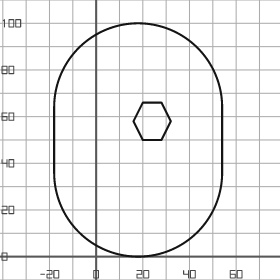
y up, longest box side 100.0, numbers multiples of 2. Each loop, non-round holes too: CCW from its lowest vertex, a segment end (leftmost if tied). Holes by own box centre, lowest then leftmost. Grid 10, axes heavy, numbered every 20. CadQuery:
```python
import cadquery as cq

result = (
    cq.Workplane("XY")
    .moveTo(-18.0, 36.0)
    .threePointArc((18.0, 0.0), (54.0, 36.0))
    .lineTo(54.0, 64.0)
    .threePointArc((18.0, 100.0), (-18.0, 64.0))
    .close()
    .moveTo(20.0, 50.0)
    .lineTo(28.0, 50.0)
    .lineTo(32.0, 58.0)
    .lineTo(28.0, 66.0)
    .lineTo(20.0, 66.0)
    .lineTo(16.0, 58.0)
    .close()
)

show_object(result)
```